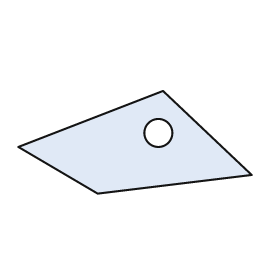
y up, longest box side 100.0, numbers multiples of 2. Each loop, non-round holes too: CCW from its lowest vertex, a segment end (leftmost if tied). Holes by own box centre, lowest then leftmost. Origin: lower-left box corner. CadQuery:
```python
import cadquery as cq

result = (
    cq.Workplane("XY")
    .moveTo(34.0, 0.0)
    .lineTo(100.0, 8.0)
    .lineTo(62.0, 44.0)
    .lineTo(0.0, 20.0)
    .close()
    .moveTo(60.0, 26.0)
    .circle(6.0)
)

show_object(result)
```